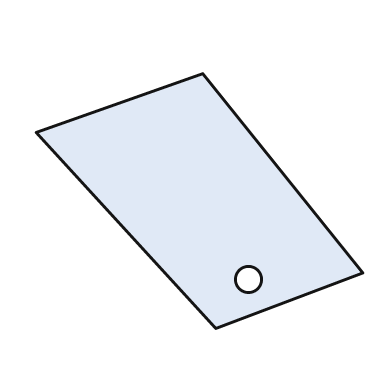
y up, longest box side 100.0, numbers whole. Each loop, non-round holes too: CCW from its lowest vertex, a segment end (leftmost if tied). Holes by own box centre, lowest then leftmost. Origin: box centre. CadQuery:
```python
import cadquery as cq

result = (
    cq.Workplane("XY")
    .moveTo(5.0, -39.0)
    .lineTo(50.0, -22.0)
    .lineTo(1.0, 39.0)
    .lineTo(-50.0, 21.0)
    .close()
    .moveTo(15.0, -24.0)
    .circle(4.0)
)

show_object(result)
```